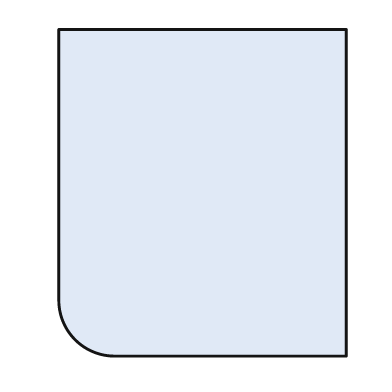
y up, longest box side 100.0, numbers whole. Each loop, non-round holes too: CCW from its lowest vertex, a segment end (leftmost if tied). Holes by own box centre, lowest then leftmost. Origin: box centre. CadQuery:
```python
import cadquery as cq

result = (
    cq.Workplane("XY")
    .moveTo(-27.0, -50.0)
    .lineTo(44.0, -50.0)
    .lineTo(44.0, 50.0)
    .lineTo(-44.0, 50.0)
    .lineTo(-44.0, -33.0)
    .threePointArc((-39.0, -45.0), (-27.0, -50.0))
    .close()
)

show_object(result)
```